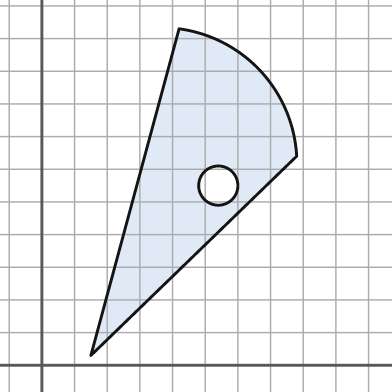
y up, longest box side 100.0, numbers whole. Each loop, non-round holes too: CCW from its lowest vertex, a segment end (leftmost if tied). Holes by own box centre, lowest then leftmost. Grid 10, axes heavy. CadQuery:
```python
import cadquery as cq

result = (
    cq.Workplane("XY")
    .moveTo(15.0, 3.0)
    .lineTo(78.0, 64.0)
    .threePointArc((67.0, 90.0), (42.0, 103.0))
    .close()
    .moveTo(54.0, 55.0)
    .circle(6.0)
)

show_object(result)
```